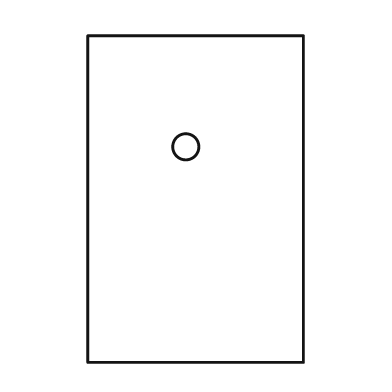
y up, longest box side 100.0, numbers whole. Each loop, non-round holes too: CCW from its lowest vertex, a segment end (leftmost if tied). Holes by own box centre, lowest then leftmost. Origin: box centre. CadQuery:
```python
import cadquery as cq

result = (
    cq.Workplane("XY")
    .moveTo(-33.0, -50.0)
    .lineTo(33.0, -50.0)
    .lineTo(33.0, 50.0)
    .lineTo(-33.0, 50.0)
    .close()
    .moveTo(-3.0, 16.0)
    .circle(4.0)
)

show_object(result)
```